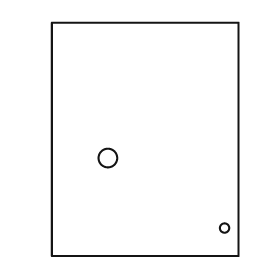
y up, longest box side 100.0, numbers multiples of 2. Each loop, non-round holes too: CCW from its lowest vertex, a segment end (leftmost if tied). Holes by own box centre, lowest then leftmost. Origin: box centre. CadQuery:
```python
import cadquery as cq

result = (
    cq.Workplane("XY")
    .moveTo(-40.0, -50.0)
    .lineTo(40.0, -50.0)
    .lineTo(40.0, 50.0)
    .lineTo(-40.0, 50.0)
    .close()
    .moveTo(34.0, -38.0)
    .circle(2.0)
    .moveTo(-16.0, -8.0)
    .circle(4.0)
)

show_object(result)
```